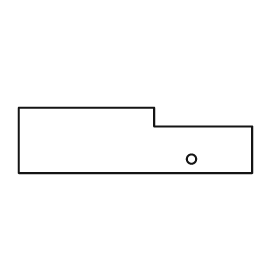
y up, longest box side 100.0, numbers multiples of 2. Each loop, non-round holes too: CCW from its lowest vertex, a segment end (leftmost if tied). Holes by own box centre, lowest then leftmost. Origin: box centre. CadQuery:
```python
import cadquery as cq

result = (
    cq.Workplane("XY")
    .moveTo(-50.0, -14.0)
    .lineTo(50.0, -14.0)
    .lineTo(50.0, 6.0)
    .lineTo(8.0, 6.0)
    .lineTo(8.0, 14.0)
    .lineTo(-50.0, 14.0)
    .close()
    .moveTo(24.0, -8.0)
    .circle(2.0)
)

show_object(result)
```